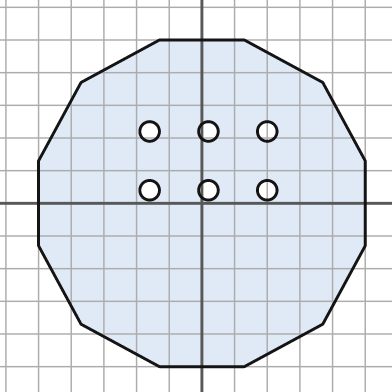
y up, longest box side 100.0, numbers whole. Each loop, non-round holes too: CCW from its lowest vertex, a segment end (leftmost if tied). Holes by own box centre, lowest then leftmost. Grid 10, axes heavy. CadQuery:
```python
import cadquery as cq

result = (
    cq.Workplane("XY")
    .moveTo(-13.0, -50.0)
    .lineTo(13.0, -50.0)
    .lineTo(37.0, -37.0)
    .lineTo(50.0, -13.0)
    .lineTo(50.0, 13.0)
    .lineTo(37.0, 37.0)
    .lineTo(13.0, 50.0)
    .lineTo(-13.0, 50.0)
    .lineTo(-37.0, 37.0)
    .lineTo(-50.0, 13.0)
    .lineTo(-50.0, -13.0)
    .lineTo(-37.0, -37.0)
    .close()
    .moveTo(-16.0, 4.0)
    .circle(3.0)
    .moveTo(2.0, 4.0)
    .circle(3.0)
    .moveTo(20.0, 4.0)
    .circle(3.0)
    .moveTo(-16.0, 22.0)
    .circle(3.0)
    .moveTo(2.0, 22.0)
    .circle(3.0)
    .moveTo(20.0, 22.0)
    .circle(3.0)
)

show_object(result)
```